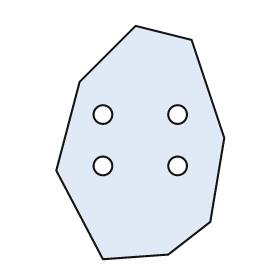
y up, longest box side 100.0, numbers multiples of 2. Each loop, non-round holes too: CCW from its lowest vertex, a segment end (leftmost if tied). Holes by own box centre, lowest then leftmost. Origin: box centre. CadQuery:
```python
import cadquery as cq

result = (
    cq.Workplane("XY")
    .moveTo(-16.0, -50.0)
    .lineTo(12.0, -48.0)
    .lineTo(30.0, -34.0)
    .lineTo(36.0, 2.0)
    .lineTo(22.0, 44.0)
    .lineTo(-2.0, 50.0)
    .lineTo(-26.0, 26.0)
    .lineTo(-36.0, -12.0)
    .close()
    .moveTo(-16.0, -10.0)
    .circle(4.0)
    .moveTo(16.0, -10.0)
    .circle(4.0)
    .moveTo(-16.0, 12.0)
    .circle(4.0)
    .moveTo(16.0, 12.0)
    .circle(4.0)
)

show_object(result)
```